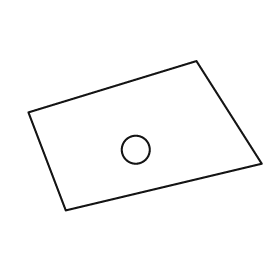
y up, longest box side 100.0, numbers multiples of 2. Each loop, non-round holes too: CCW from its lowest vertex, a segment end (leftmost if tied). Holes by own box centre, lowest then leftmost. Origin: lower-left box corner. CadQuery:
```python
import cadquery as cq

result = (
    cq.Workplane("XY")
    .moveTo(16.0, 0.0)
    .lineTo(100.0, 20.0)
    .lineTo(72.0, 64.0)
    .lineTo(0.0, 42.0)
    .close()
    .moveTo(46.0, 26.0)
    .circle(6.0)
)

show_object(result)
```